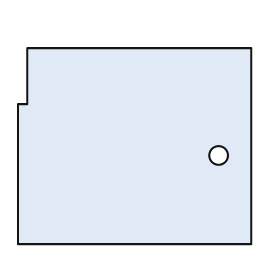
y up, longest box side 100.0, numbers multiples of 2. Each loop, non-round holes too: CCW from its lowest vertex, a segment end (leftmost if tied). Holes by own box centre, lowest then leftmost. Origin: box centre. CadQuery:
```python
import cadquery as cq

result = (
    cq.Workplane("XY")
    .moveTo(-50.0, -42.0)
    .lineTo(50.0, -42.0)
    .lineTo(50.0, 42.0)
    .lineTo(-46.0, 42.0)
    .lineTo(-46.0, 18.0)
    .lineTo(-50.0, 18.0)
    .close()
    .moveTo(36.0, -4.0)
    .circle(4.0)
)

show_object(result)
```